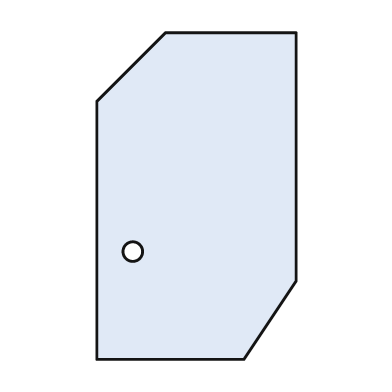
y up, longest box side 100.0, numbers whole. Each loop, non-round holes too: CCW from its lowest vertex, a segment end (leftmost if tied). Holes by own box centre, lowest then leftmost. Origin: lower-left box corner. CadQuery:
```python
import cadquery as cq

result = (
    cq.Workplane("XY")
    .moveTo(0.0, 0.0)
    .lineTo(45.0, 0.0)
    .lineTo(61.0, 24.0)
    .lineTo(61.0, 100.0)
    .lineTo(21.0, 100.0)
    .lineTo(0.0, 79.0)
    .close()
    .moveTo(11.0, 33.0)
    .circle(3.0)
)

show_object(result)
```